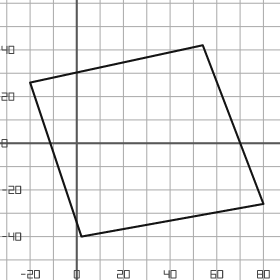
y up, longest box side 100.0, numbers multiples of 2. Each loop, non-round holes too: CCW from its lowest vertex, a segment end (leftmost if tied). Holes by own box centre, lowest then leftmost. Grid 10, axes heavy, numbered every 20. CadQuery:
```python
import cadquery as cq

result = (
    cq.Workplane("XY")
    .moveTo(2.0, -40.0)
    .lineTo(80.0, -26.0)
    .lineTo(54.0, 42.0)
    .lineTo(-20.0, 26.0)
    .close()
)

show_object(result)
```